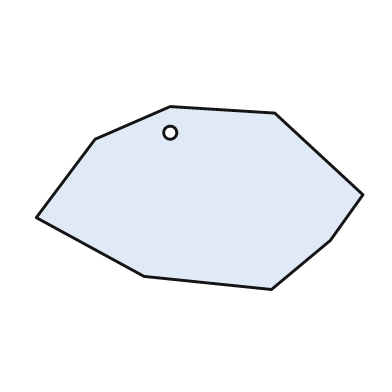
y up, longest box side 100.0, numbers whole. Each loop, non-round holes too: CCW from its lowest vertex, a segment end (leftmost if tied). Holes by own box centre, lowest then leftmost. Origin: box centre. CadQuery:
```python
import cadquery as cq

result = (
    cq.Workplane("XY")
    .moveTo(22.0, -28.0)
    .lineTo(40.0, -13.0)
    .lineTo(50.0, 1.0)
    .lineTo(23.0, 26.0)
    .lineTo(-9.0, 28.0)
    .lineTo(-32.0, 18.0)
    .lineTo(-50.0, -6.0)
    .lineTo(-17.0, -24.0)
    .close()
    .moveTo(-9.0, 20.0)
    .circle(2.0)
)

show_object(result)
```